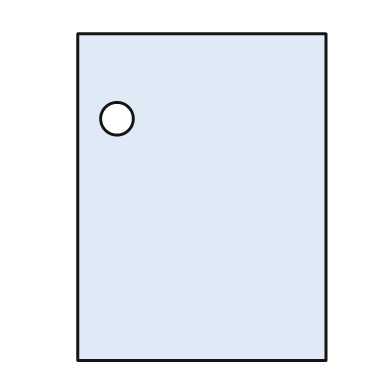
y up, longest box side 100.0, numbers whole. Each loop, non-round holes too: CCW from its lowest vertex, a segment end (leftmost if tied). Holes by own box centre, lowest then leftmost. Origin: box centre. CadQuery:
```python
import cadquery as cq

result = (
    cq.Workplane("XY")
    .moveTo(-38.0, -50.0)
    .lineTo(38.0, -50.0)
    .lineTo(38.0, 50.0)
    .lineTo(-38.0, 50.0)
    .close()
    .moveTo(-26.0, 24.0)
    .circle(5.0)
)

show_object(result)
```